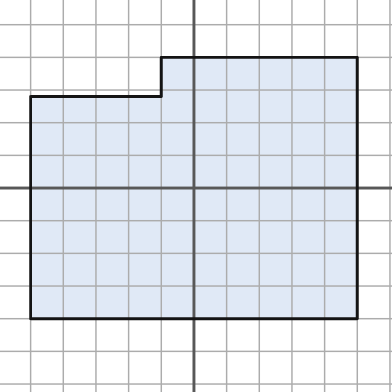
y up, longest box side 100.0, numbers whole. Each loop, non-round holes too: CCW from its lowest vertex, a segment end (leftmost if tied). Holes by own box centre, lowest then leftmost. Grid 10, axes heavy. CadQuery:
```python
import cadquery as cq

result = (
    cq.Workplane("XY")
    .moveTo(-50.0, -40.0)
    .lineTo(50.0, -40.0)
    .lineTo(50.0, 40.0)
    .lineTo(-10.0, 40.0)
    .lineTo(-10.0, 28.0)
    .lineTo(-50.0, 28.0)
    .close()
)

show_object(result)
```